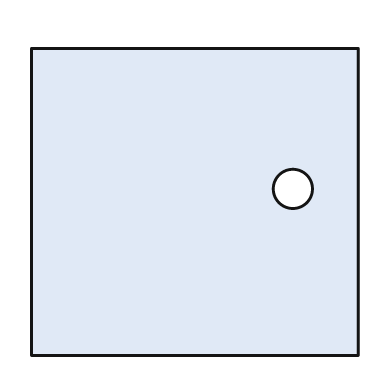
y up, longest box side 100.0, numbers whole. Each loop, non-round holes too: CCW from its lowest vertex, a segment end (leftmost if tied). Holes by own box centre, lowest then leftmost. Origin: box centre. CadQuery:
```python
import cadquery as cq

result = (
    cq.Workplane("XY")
    .moveTo(-50.0, -47.0)
    .lineTo(50.0, -47.0)
    .lineTo(50.0, 47.0)
    .lineTo(-50.0, 47.0)
    .close()
    .moveTo(30.0, 4.0)
    .circle(6.0)
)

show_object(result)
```